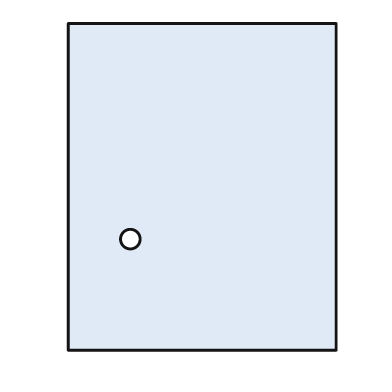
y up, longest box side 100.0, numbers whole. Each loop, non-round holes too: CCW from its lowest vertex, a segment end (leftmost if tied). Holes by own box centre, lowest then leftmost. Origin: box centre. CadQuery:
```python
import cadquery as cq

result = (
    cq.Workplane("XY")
    .moveTo(-41.0, -50.0)
    .lineTo(41.0, -50.0)
    .lineTo(41.0, 50.0)
    .lineTo(-41.0, 50.0)
    .close()
    .moveTo(-22.0, -16.0)
    .circle(3.0)
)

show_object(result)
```